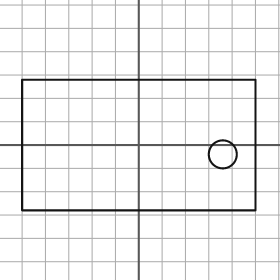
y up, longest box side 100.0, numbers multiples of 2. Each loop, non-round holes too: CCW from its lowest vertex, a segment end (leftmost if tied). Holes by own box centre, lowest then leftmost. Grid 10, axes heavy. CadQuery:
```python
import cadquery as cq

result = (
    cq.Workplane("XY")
    .moveTo(-50.0, -28.0)
    .lineTo(50.0, -28.0)
    .lineTo(50.0, 28.0)
    .lineTo(-50.0, 28.0)
    .close()
    .moveTo(36.0, -4.0)
    .circle(6.0)
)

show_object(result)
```